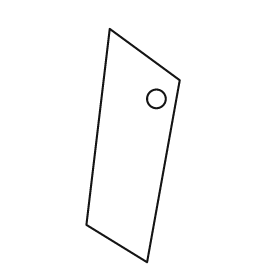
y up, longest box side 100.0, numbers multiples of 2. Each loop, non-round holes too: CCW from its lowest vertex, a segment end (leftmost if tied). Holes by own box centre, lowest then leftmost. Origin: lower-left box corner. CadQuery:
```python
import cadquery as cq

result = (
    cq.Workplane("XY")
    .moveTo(26.0, 0.0)
    .lineTo(40.0, 78.0)
    .lineTo(10.0, 100.0)
    .lineTo(0.0, 16.0)
    .close()
    .moveTo(30.0, 70.0)
    .circle(4.0)
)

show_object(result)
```